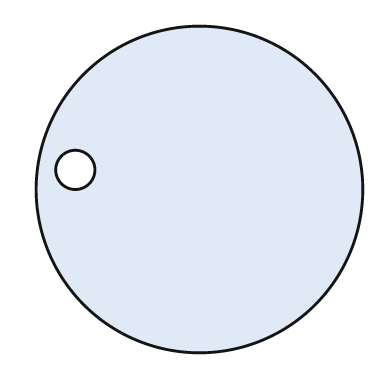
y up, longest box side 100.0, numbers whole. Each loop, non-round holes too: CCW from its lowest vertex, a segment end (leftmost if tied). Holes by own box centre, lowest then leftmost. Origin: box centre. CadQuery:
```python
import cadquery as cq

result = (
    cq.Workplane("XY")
    .moveTo(0.0, 0.0)
    .circle(50.0)
    .moveTo(-38.0, 6.0)
    .circle(6.0)
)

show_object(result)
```